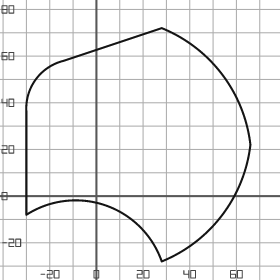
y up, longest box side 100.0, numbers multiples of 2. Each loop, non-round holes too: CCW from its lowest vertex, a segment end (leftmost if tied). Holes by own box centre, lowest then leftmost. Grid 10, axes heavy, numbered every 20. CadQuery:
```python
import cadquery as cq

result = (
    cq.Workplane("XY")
    .moveTo(28.0, -28.0)
    .threePointArc((54.0, -8.0), (66.0, 22.0))
    .threePointArc((54.0, 52.0), (28.0, 72.0))
    .lineTo(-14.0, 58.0)
    .threePointArc((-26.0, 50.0), (-30.0, 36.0))
    .lineTo(-30.0, -8.0)
    .threePointArc((4.0, -4.0), (28.0, -28.0))
    .close()
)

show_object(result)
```